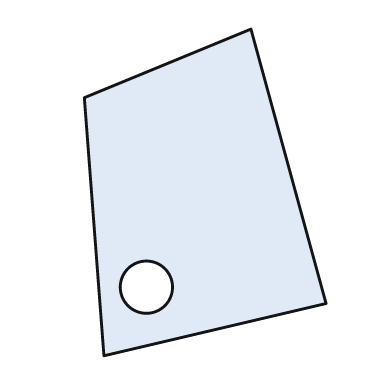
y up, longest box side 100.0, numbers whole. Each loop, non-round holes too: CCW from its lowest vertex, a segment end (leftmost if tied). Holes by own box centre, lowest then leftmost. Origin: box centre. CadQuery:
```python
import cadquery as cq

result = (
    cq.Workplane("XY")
    .moveTo(-31.0, -50.0)
    .lineTo(37.0, -34.0)
    .lineTo(14.0, 50.0)
    .lineTo(-37.0, 29.0)
    .close()
    .moveTo(-18.0, -29.0)
    .circle(8.0)
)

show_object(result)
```